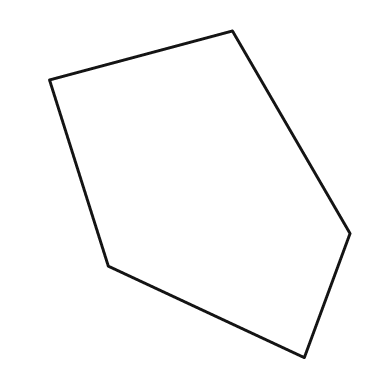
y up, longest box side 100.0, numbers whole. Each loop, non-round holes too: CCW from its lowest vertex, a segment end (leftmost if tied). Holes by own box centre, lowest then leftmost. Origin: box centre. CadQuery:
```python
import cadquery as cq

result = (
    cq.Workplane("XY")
    .moveTo(32.0, -50.0)
    .lineTo(46.0, -12.0)
    .lineTo(10.0, 50.0)
    .lineTo(-46.0, 35.0)
    .lineTo(-28.0, -22.0)
    .close()
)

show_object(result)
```